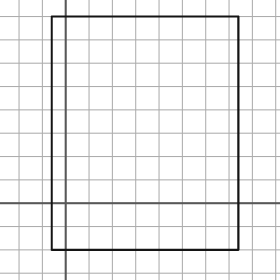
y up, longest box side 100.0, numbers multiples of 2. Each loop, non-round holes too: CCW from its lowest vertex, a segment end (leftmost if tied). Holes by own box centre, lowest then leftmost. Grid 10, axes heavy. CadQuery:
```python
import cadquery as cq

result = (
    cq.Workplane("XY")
    .moveTo(-6.0, -20.0)
    .lineTo(74.0, -20.0)
    .lineTo(74.0, 80.0)
    .lineTo(-6.0, 80.0)
    .close()
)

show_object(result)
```